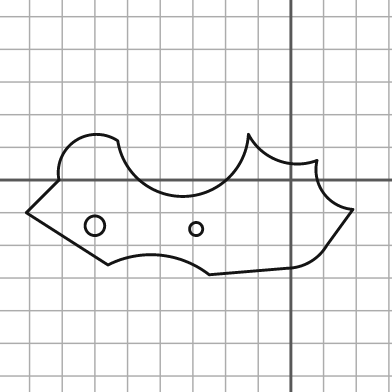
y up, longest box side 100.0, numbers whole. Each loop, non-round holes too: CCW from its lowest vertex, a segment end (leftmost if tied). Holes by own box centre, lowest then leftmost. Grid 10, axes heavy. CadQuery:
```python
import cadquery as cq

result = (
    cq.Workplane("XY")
    .moveTo(-25.0, -29.0)
    .lineTo(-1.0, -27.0)
    .threePointArc((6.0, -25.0), (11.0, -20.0))
    .lineTo(19.0, -9.0)
    .threePointArc((10.0, -4.0), (8.0, 6.0))
    .threePointArc((-4.0, 6.0), (-13.0, 14.0))
    .threePointArc((-32.0, -5.0), (-53.0, 12.0))
    .threePointArc((-66.0, 12.0), (-71.0, 0.0))
    .lineTo(-81.0, -10.0)
    .lineTo(-56.0, -26.0)
    .threePointArc((-40.0, -23.0), (-25.0, -29.0))
    .close()
    .moveTo(-29.0, -15.0)
    .circle(2.0)
    .moveTo(-60.0, -14.0)
    .circle(3.0)
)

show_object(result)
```